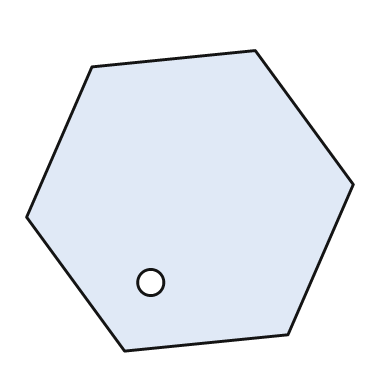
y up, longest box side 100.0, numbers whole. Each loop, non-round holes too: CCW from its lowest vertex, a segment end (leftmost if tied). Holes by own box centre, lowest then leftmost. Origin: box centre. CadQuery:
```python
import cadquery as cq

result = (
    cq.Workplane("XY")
    .moveTo(-20.0, -46.0)
    .lineTo(30.0, -41.0)
    .lineTo(50.0, 5.0)
    .lineTo(20.0, 46.0)
    .lineTo(-30.0, 41.0)
    .lineTo(-50.0, -5.0)
    .close()
    .moveTo(-12.0, -25.0)
    .circle(4.0)
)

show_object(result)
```